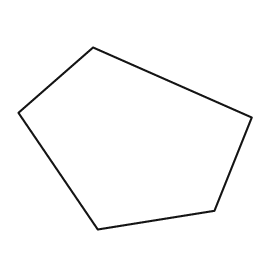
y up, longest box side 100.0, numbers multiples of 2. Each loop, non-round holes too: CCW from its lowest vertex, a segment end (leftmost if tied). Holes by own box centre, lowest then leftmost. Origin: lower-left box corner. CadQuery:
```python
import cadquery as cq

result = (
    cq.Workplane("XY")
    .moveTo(34.0, 0.0)
    .lineTo(84.0, 8.0)
    .lineTo(100.0, 48.0)
    .lineTo(32.0, 78.0)
    .lineTo(0.0, 50.0)
    .close()
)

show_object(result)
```